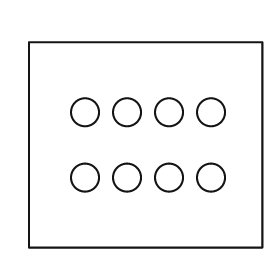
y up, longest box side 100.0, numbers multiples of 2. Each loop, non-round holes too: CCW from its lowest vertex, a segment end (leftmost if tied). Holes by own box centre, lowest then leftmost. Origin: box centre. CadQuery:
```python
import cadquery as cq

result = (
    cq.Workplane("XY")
    .moveTo(-50.0, -44.0)
    .lineTo(50.0, -44.0)
    .lineTo(50.0, 44.0)
    .lineTo(-50.0, 44.0)
    .close()
    .moveTo(-26.0, -14.0)
    .circle(6.0)
    .moveTo(-8.0, -14.0)
    .circle(6.0)
    .moveTo(10.0, -14.0)
    .circle(6.0)
    .moveTo(28.0, -14.0)
    .circle(6.0)
    .moveTo(-26.0, 14.0)
    .circle(6.0)
    .moveTo(-8.0, 14.0)
    .circle(6.0)
    .moveTo(10.0, 14.0)
    .circle(6.0)
    .moveTo(28.0, 14.0)
    .circle(6.0)
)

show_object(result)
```